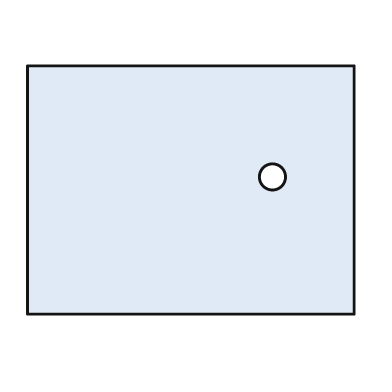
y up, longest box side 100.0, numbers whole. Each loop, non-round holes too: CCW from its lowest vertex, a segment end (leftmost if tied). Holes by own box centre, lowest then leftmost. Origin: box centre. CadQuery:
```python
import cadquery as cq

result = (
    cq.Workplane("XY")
    .moveTo(-50.0, -38.0)
    .lineTo(50.0, -38.0)
    .lineTo(50.0, 38.0)
    .lineTo(-50.0, 38.0)
    .close()
    .moveTo(25.0, 4.0)
    .circle(4.0)
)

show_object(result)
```